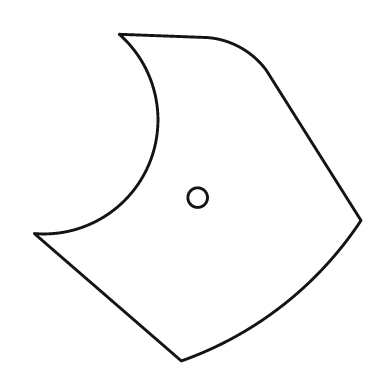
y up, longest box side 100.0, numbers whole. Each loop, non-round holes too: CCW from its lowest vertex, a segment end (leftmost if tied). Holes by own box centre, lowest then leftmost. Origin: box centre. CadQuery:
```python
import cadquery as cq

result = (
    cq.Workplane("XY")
    .moveTo(-5.0, -50.0)
    .threePointArc((26.0, -33.0), (50.0, -7.0))
    .lineTo(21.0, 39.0)
    .threePointArc((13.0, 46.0), (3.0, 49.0))
    .lineTo(-24.0, 50.0)
    .threePointArc((-15.0, 10.0), (-50.0, -11.0))
    .close()
    .moveTo(0.0, 0.0)
    .circle(3.0)
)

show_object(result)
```